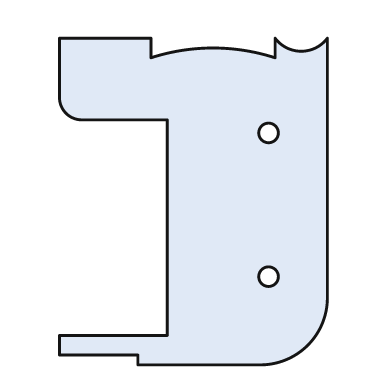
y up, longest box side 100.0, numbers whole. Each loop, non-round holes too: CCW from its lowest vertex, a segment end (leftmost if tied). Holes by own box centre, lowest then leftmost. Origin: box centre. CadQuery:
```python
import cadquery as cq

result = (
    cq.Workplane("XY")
    .moveTo(-17.0, -50.0)
    .lineTo(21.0, -50.0)
    .threePointArc((35.0, -44.0), (41.0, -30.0))
    .lineTo(41.0, 50.0)
    .threePointArc((33.0, 46.0), (25.0, 50.0))
    .lineTo(25.0, 44.0)
    .threePointArc((6.0, 47.0), (-13.0, 44.0))
    .lineTo(-13.0, 50.0)
    .lineTo(-41.0, 50.0)
    .lineTo(-41.0, 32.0)
    .threePointArc((-39.0, 27.0), (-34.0, 25.0))
    .lineTo(-8.0, 25.0)
    .lineTo(-8.0, -41.0)
    .lineTo(-41.0, -41.0)
    .lineTo(-41.0, -47.0)
    .lineTo(-17.0, -47.0)
    .close()
    .moveTo(23.0, -23.0)
    .circle(3.0)
    .moveTo(23.0, 21.0)
    .circle(3.0)
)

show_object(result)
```